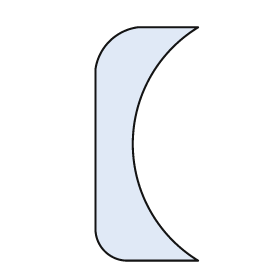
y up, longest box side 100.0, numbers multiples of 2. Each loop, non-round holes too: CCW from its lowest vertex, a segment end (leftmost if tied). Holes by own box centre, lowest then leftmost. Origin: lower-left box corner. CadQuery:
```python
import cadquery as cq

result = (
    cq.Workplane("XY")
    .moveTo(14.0, 0.0)
    .lineTo(44.0, 0.0)
    .threePointArc((16.0, 50.0), (44.0, 100.0))
    .lineTo(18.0, 100.0)
    .threePointArc((6.0, 94.0), (0.0, 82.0))
    .lineTo(0.0, 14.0)
    .threePointArc((4.0, 4.0), (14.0, 0.0))
    .close()
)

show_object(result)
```